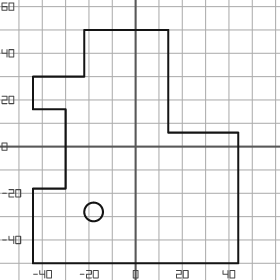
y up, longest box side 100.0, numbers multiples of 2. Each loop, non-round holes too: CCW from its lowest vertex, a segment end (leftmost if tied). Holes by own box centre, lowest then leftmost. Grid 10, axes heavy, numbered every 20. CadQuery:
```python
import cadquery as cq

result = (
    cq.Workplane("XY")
    .moveTo(-44.0, -50.0)
    .lineTo(44.0, -50.0)
    .lineTo(44.0, 6.0)
    .lineTo(14.0, 6.0)
    .lineTo(14.0, 50.0)
    .lineTo(-22.0, 50.0)
    .lineTo(-22.0, 30.0)
    .lineTo(-44.0, 30.0)
    .lineTo(-44.0, 16.0)
    .lineTo(-30.0, 16.0)
    .lineTo(-30.0, -18.0)
    .lineTo(-44.0, -18.0)
    .close()
    .moveTo(-18.0, -28.0)
    .circle(4.0)
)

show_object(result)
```